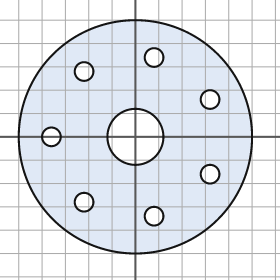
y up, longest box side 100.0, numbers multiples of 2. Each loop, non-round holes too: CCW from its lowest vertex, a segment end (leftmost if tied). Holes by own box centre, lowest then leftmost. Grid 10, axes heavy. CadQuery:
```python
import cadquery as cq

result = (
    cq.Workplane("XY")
    .moveTo(0.0, 0.0)
    .circle(50.0)
    .moveTo(8.0, -34.0)
    .circle(4.0)
    .moveTo(-22.0, -28.0)
    .circle(4.0)
    .moveTo(32.0, -16.0)
    .circle(4.0)
    .moveTo(-36.0, 0.0)
    .circle(4.0)
    .moveTo(0.0, 0.0)
    .circle(12.0)
    .moveTo(32.0, 16.0)
    .circle(4.0)
    .moveTo(-22.0, 28.0)
    .circle(4.0)
    .moveTo(8.0, 34.0)
    .circle(4.0)
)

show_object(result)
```